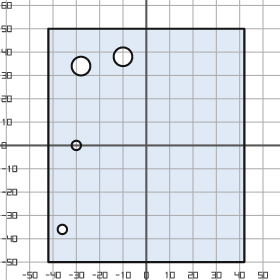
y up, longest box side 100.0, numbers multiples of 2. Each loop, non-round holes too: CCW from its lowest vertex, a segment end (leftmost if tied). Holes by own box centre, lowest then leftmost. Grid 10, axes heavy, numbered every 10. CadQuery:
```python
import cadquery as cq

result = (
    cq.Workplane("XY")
    .moveTo(-42.0, -50.0)
    .lineTo(42.0, -50.0)
    .lineTo(42.0, 50.0)
    .lineTo(-42.0, 50.0)
    .close()
    .moveTo(-36.0, -36.0)
    .circle(2.0)
    .moveTo(-30.0, 0.0)
    .circle(2.0)
    .moveTo(-28.0, 34.0)
    .circle(4.0)
    .moveTo(-10.0, 38.0)
    .circle(4.0)
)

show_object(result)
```